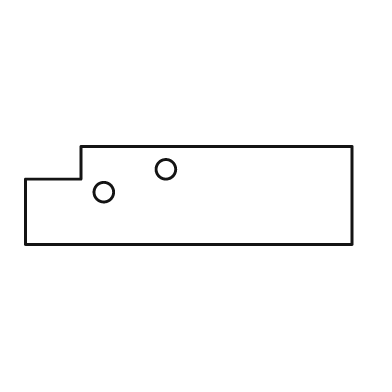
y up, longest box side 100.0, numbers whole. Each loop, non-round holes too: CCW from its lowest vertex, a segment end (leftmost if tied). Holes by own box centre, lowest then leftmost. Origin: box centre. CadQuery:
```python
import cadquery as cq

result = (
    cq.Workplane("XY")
    .moveTo(-50.0, -15.0)
    .lineTo(50.0, -15.0)
    .lineTo(50.0, 15.0)
    .lineTo(-33.0, 15.0)
    .lineTo(-33.0, 5.0)
    .lineTo(-50.0, 5.0)
    .close()
    .moveTo(-26.0, 1.0)
    .circle(3.0)
    .moveTo(-7.0, 8.0)
    .circle(3.0)
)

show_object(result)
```